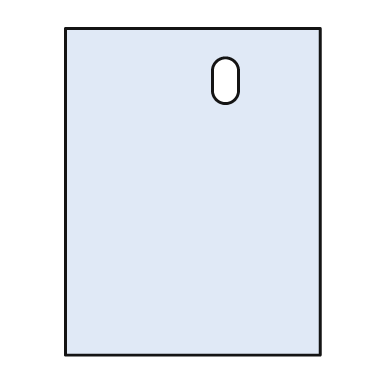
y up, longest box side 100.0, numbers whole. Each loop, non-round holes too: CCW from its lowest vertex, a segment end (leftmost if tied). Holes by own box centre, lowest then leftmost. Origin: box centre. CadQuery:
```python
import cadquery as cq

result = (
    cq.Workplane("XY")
    .moveTo(-39.0, -50.0)
    .lineTo(39.0, -50.0)
    .lineTo(39.0, 50.0)
    .lineTo(-39.0, 50.0)
    .close()
    .moveTo(6.0, 31.0)
    .threePointArc((10.0, 27.0), (14.0, 31.0))
    .lineTo(14.0, 37.0)
    .threePointArc((10.0, 41.0), (6.0, 37.0))
    .close()
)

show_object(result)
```